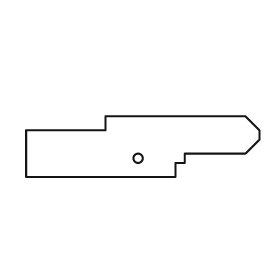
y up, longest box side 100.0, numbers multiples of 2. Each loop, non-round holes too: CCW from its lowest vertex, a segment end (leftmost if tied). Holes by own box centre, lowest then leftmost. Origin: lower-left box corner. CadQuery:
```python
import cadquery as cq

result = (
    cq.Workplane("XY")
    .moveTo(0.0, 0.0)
    .lineTo(64.0, 0.0)
    .lineTo(64.0, 6.0)
    .lineTo(68.0, 6.0)
    .lineTo(68.0, 10.0)
    .lineTo(94.0, 10.0)
    .lineTo(100.0, 16.0)
    .lineTo(100.0, 20.0)
    .lineTo(94.0, 26.0)
    .lineTo(34.0, 26.0)
    .lineTo(34.0, 20.0)
    .lineTo(0.0, 20.0)
    .close()
    .moveTo(48.0, 8.0)
    .circle(2.0)
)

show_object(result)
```